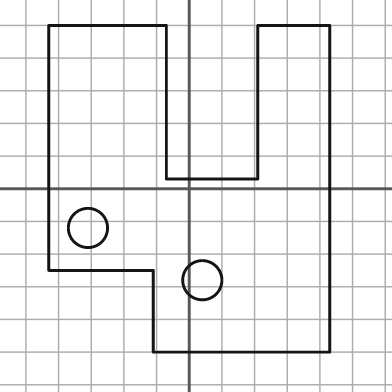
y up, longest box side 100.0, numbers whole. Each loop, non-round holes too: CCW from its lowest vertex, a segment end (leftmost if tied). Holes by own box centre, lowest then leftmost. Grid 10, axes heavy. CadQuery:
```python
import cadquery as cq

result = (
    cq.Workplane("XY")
    .moveTo(-11.0, -50.0)
    .lineTo(43.0, -50.0)
    .lineTo(43.0, 50.0)
    .lineTo(21.0, 50.0)
    .lineTo(21.0, 3.0)
    .lineTo(-7.0, 3.0)
    .lineTo(-7.0, 50.0)
    .lineTo(-43.0, 50.0)
    .lineTo(-43.0, -25.0)
    .lineTo(-11.0, -25.0)
    .close()
    .moveTo(4.0, -28.0)
    .circle(6.0)
    .moveTo(-31.0, -12.0)
    .circle(6.0)
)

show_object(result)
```